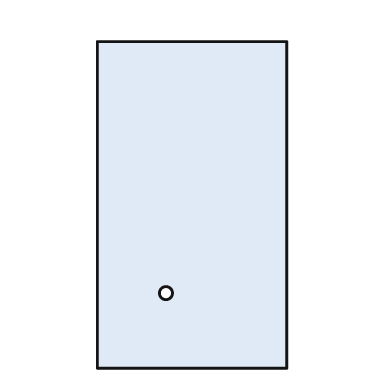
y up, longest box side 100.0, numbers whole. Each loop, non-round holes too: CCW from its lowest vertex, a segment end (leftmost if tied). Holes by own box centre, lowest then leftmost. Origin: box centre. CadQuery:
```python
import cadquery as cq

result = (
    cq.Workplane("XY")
    .moveTo(-29.0, -50.0)
    .lineTo(29.0, -50.0)
    .lineTo(29.0, 50.0)
    .lineTo(-29.0, 50.0)
    .close()
    .moveTo(-8.0, -27.0)
    .circle(2.0)
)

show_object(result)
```